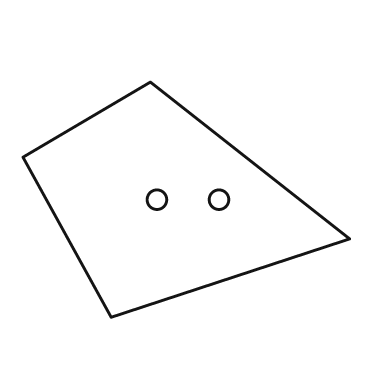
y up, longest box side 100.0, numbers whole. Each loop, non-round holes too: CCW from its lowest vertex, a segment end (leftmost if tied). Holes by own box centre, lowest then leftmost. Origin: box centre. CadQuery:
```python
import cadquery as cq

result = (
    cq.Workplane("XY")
    .moveTo(-23.0, -36.0)
    .lineTo(50.0, -12.0)
    .lineTo(-11.0, 36.0)
    .lineTo(-50.0, 13.0)
    .close()
    .moveTo(-9.0, 0.0)
    .circle(3.0)
    .moveTo(10.0, 0.0)
    .circle(3.0)
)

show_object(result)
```